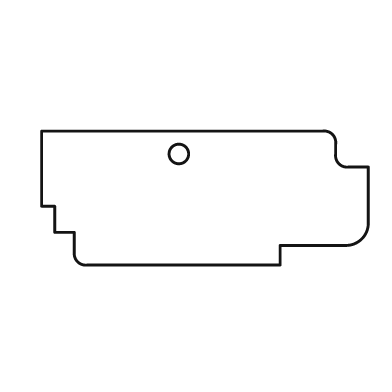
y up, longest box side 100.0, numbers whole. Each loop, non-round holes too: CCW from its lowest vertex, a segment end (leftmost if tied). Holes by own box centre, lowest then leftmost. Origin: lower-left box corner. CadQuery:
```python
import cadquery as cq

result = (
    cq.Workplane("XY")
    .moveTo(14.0, 0.0)
    .lineTo(73.0, 0.0)
    .lineTo(73.0, 6.0)
    .lineTo(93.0, 6.0)
    .threePointArc((98.0, 8.0), (100.0, 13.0))
    .lineTo(100.0, 30.0)
    .lineTo(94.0, 30.0)
    .threePointArc((91.0, 31.0), (90.0, 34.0))
    .lineTo(90.0, 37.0)
    .threePointArc((89.0, 40.0), (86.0, 41.0))
    .lineTo(0.0, 41.0)
    .lineTo(0.0, 18.0)
    .lineTo(4.0, 18.0)
    .lineTo(4.0, 10.0)
    .lineTo(10.0, 10.0)
    .lineTo(10.0, 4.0)
    .threePointArc((11.0, 1.0), (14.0, 0.0))
    .close()
    .moveTo(42.0, 34.0)
    .circle(3.0)
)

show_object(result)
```